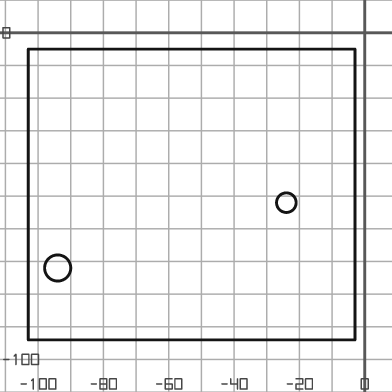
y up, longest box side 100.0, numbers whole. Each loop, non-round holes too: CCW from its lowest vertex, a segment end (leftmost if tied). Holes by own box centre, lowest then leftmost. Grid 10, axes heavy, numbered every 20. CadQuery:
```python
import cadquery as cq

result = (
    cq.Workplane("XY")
    .moveTo(-103.0, -94.0)
    .lineTo(-3.0, -94.0)
    .lineTo(-3.0, -5.0)
    .lineTo(-103.0, -5.0)
    .close()
    .moveTo(-94.0, -72.0)
    .circle(4.0)
    .moveTo(-24.0, -52.0)
    .circle(3.0)
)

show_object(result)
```